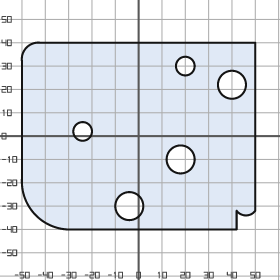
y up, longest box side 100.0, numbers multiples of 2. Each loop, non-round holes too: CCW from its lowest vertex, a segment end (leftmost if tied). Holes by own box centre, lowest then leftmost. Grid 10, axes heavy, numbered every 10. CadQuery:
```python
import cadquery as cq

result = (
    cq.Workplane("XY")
    .moveTo(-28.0, -40.0)
    .lineTo(42.0, -40.0)
    .lineTo(42.0, -32.0)
    .threePointArc((46.0, -34.0), (50.0, -32.0))
    .lineTo(50.0, 40.0)
    .lineTo(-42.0, 40.0)
    .threePointArc((-48.0, 38.0), (-50.0, 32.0))
    .lineTo(-50.0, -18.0)
    .threePointArc((-44.0, -34.0), (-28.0, -40.0))
    .close()
    .moveTo(-4.0, -30.0)
    .circle(6.0)
    .moveTo(18.0, -10.0)
    .circle(6.0)
    .moveTo(-24.0, 2.0)
    .circle(4.0)
    .moveTo(40.0, 22.0)
    .circle(6.0)
    .moveTo(20.0, 30.0)
    .circle(4.0)
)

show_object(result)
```